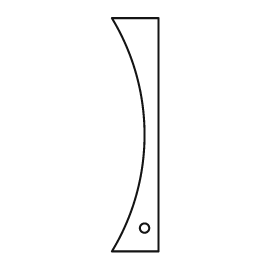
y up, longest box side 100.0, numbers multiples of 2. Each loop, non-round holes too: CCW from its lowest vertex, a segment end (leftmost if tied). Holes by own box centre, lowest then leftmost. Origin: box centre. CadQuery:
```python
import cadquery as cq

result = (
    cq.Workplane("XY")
    .moveTo(-10.0, -50.0)
    .lineTo(10.0, -50.0)
    .lineTo(10.0, 50.0)
    .lineTo(-10.0, 50.0)
    .threePointArc((4.0, 0.0), (-10.0, -50.0))
    .close()
    .moveTo(4.0, -40.0)
    .circle(2.0)
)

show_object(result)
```